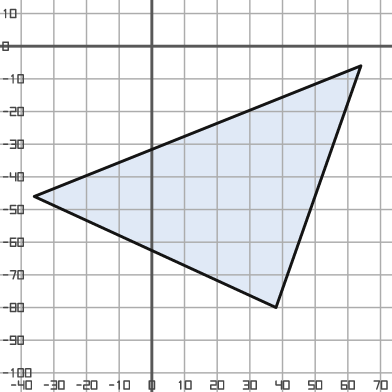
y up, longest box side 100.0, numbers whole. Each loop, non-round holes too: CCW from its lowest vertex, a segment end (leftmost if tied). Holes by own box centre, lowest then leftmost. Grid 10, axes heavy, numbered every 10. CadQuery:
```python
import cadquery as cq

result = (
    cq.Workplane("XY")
    .moveTo(38.0, -80.0)
    .lineTo(64.0, -6.0)
    .lineTo(-36.0, -46.0)
    .close()
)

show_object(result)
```